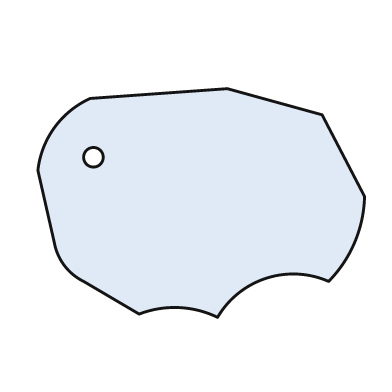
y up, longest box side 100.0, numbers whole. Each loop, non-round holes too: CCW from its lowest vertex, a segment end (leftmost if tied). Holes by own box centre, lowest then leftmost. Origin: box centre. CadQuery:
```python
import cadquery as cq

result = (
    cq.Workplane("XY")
    .moveTo(5.0, -35.0)
    .threePointArc((20.0, -23.0), (39.0, -24.0))
    .threePointArc((47.0, -12.0), (50.0, 2.0))
    .lineTo(37.0, 27.0)
    .lineTo(8.0, 35.0)
    .lineTo(-34.0, 32.0)
    .threePointArc((-45.0, 23.0), (-50.0, 10.0))
    .lineTo(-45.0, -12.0)
    .threePointArc((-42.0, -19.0), (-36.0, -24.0))
    .lineTo(-19.0, -34.0)
    .threePointArc((-7.0, -32.0), (5.0, -35.0))
    .close()
    .moveTo(-33.0, 14.0)
    .circle(3.0)
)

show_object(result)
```